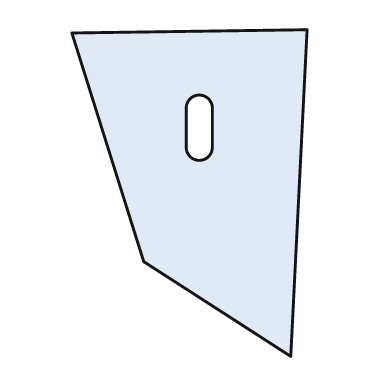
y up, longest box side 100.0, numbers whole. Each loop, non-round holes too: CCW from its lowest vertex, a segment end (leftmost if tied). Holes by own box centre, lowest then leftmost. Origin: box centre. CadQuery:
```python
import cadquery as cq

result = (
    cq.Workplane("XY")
    .moveTo(31.0, -50.0)
    .lineTo(36.0, 50.0)
    .lineTo(-36.0, 49.0)
    .lineTo(-14.0, -21.0)
    .close()
    .moveTo(-1.0, 14.0)
    .threePointArc((3.0, 10.0), (7.0, 14.0))
    .lineTo(7.0, 26.0)
    .threePointArc((3.0, 30.0), (-1.0, 26.0))
    .close()
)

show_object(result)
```